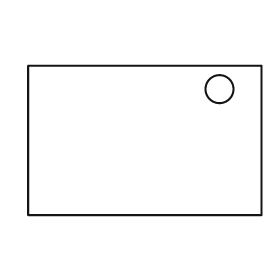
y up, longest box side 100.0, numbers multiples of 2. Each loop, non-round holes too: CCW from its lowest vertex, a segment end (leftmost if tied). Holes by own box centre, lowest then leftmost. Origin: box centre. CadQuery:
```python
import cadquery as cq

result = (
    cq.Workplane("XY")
    .moveTo(-50.0, -32.0)
    .lineTo(50.0, -32.0)
    .lineTo(50.0, 32.0)
    .lineTo(-50.0, 32.0)
    .close()
    .moveTo(32.0, 22.0)
    .circle(6.0)
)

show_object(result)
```